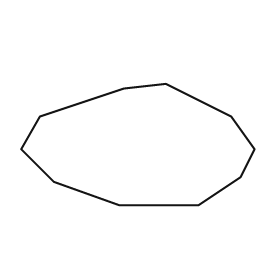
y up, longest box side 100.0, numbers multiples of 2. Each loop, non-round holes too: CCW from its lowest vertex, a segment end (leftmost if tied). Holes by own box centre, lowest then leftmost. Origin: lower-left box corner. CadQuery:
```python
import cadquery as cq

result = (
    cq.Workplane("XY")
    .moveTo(42.0, 0.0)
    .lineTo(76.0, 0.0)
    .lineTo(94.0, 12.0)
    .lineTo(100.0, 24.0)
    .lineTo(90.0, 38.0)
    .lineTo(62.0, 52.0)
    .lineTo(44.0, 50.0)
    .lineTo(8.0, 38.0)
    .lineTo(0.0, 24.0)
    .lineTo(14.0, 10.0)
    .close()
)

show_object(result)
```